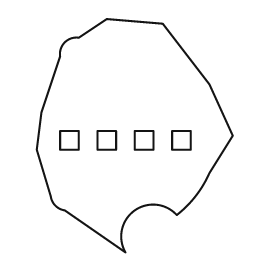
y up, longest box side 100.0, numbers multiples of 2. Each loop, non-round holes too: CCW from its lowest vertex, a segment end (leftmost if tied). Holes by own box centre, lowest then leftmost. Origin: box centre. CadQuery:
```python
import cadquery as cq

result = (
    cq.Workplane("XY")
    .moveTo(-4.0, -50.0)
    .threePointArc((0.0, -32.0), (18.0, -34.0))
    .threePointArc((26.0, -26.0), (32.0, -16.0))
    .lineTo(42.0, 0.0)
    .lineTo(32.0, 22.0)
    .lineTo(12.0, 48.0)
    .lineTo(-12.0, 50.0)
    .lineTo(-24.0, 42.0)
    .threePointArc((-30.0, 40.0), (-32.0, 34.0))
    .lineTo(-40.0, 10.0)
    .lineTo(-42.0, -6.0)
    .lineTo(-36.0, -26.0)
    .threePointArc((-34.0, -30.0), (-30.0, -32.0))
    .close()
    .moveTo(-32.0, -6.0)
    .lineTo(-24.0, -6.0)
    .lineTo(-24.0, 2.0)
    .lineTo(-32.0, 2.0)
    .close()
    .moveTo(-16.0, -6.0)
    .lineTo(-8.0, -6.0)
    .lineTo(-8.0, 2.0)
    .lineTo(-16.0, 2.0)
    .close()
    .moveTo(0.0, -6.0)
    .lineTo(8.0, -6.0)
    .lineTo(8.0, 2.0)
    .lineTo(0.0, 2.0)
    .close()
    .moveTo(16.0, -6.0)
    .lineTo(24.0, -6.0)
    .lineTo(24.0, 2.0)
    .lineTo(16.0, 2.0)
    .close()
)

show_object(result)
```